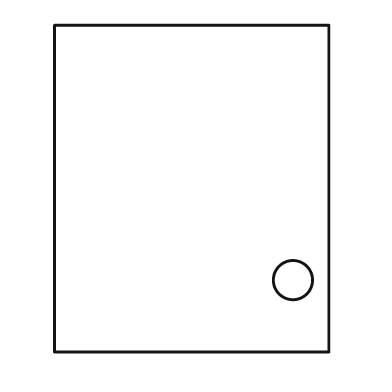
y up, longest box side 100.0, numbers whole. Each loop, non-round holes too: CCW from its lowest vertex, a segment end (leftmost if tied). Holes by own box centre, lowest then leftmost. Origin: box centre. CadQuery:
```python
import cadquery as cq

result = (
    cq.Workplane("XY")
    .moveTo(-42.0, -50.0)
    .lineTo(42.0, -50.0)
    .lineTo(42.0, 50.0)
    .lineTo(-42.0, 50.0)
    .close()
    .moveTo(31.0, -28.0)
    .circle(6.0)
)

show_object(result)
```